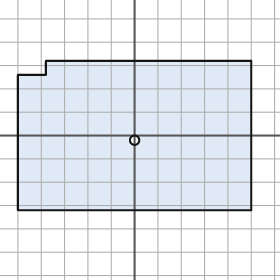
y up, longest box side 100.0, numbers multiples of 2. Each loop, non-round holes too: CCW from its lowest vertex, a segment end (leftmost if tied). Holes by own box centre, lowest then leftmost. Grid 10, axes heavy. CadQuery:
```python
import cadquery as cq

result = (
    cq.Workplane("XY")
    .moveTo(-50.0, -32.0)
    .lineTo(50.0, -32.0)
    .lineTo(50.0, 32.0)
    .lineTo(-38.0, 32.0)
    .lineTo(-38.0, 26.0)
    .lineTo(-50.0, 26.0)
    .close()
    .moveTo(0.0, -2.0)
    .circle(2.0)
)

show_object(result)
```